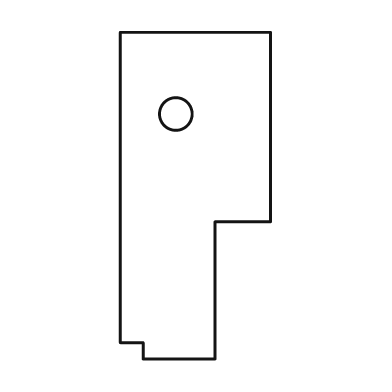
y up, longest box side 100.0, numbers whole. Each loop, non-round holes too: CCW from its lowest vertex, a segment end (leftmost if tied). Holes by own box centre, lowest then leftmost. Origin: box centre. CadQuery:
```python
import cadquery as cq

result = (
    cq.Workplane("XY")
    .moveTo(-16.0, -50.0)
    .lineTo(6.0, -50.0)
    .lineTo(6.0, -8.0)
    .lineTo(23.0, -8.0)
    .lineTo(23.0, 50.0)
    .lineTo(-23.0, 50.0)
    .lineTo(-23.0, -45.0)
    .lineTo(-16.0, -45.0)
    .close()
    .moveTo(-6.0, 25.0)
    .circle(5.0)
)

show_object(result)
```